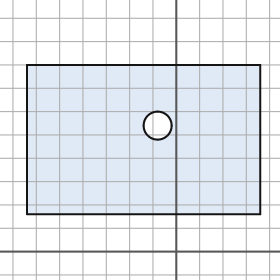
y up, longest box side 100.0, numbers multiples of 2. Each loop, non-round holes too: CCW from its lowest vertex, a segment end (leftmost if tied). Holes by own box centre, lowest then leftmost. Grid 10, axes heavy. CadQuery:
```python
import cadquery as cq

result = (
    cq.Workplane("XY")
    .moveTo(-64.0, 16.0)
    .lineTo(36.0, 16.0)
    .lineTo(36.0, 80.0)
    .lineTo(-64.0, 80.0)
    .close()
    .moveTo(-8.0, 54.0)
    .circle(6.0)
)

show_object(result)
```